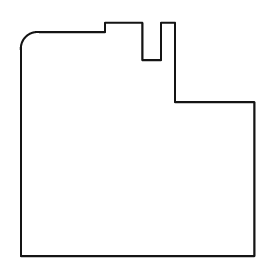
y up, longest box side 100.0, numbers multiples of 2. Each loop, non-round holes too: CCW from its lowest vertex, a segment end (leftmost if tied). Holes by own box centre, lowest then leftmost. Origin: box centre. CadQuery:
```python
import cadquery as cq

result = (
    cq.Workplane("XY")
    .moveTo(-50.0, -50.0)
    .lineTo(50.0, -50.0)
    .lineTo(50.0, 16.0)
    .lineTo(16.0, 16.0)
    .lineTo(16.0, 50.0)
    .lineTo(10.0, 50.0)
    .lineTo(10.0, 34.0)
    .lineTo(2.0, 34.0)
    .lineTo(2.0, 50.0)
    .lineTo(-14.0, 50.0)
    .lineTo(-14.0, 46.0)
    .lineTo(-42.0, 46.0)
    .threePointArc((-48.0, 44.0), (-50.0, 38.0))
    .close()
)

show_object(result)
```